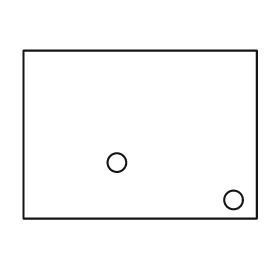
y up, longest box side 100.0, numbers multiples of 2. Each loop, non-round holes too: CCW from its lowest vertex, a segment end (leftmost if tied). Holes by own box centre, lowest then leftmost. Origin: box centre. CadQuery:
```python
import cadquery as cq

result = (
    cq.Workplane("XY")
    .moveTo(-50.0, -36.0)
    .lineTo(50.0, -36.0)
    .lineTo(50.0, 36.0)
    .lineTo(-50.0, 36.0)
    .close()
    .moveTo(40.0, -28.0)
    .circle(4.0)
    .moveTo(-10.0, -12.0)
    .circle(4.0)
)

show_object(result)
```